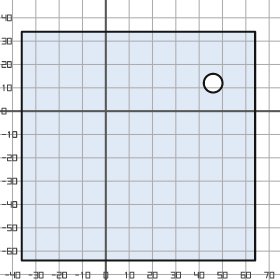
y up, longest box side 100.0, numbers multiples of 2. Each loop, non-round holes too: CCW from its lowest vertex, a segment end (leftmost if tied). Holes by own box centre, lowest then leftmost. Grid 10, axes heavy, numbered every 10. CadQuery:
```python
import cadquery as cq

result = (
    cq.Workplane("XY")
    .moveTo(-36.0, -64.0)
    .lineTo(64.0, -64.0)
    .lineTo(64.0, 34.0)
    .lineTo(-36.0, 34.0)
    .close()
    .moveTo(46.0, 12.0)
    .circle(4.0)
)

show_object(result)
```